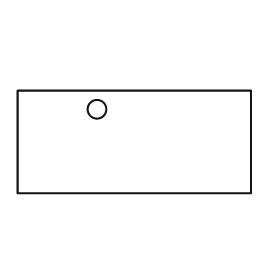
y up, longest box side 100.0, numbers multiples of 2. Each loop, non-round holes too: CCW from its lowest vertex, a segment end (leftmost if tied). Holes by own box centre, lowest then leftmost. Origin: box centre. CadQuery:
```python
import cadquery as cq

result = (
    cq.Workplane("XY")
    .moveTo(-50.0, -22.0)
    .lineTo(50.0, -22.0)
    .lineTo(50.0, 22.0)
    .lineTo(-50.0, 22.0)
    .close()
    .moveTo(-16.0, 14.0)
    .circle(4.0)
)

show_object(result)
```